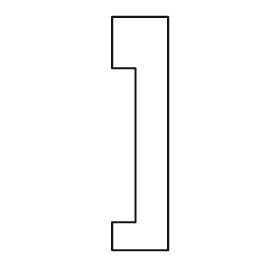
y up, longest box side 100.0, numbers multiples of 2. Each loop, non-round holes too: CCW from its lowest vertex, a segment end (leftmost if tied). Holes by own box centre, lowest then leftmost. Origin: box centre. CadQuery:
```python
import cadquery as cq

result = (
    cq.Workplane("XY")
    .moveTo(-12.0, -50.0)
    .lineTo(12.0, -50.0)
    .lineTo(12.0, 50.0)
    .lineTo(-12.0, 50.0)
    .lineTo(-12.0, 28.0)
    .lineTo(-2.0, 28.0)
    .lineTo(-2.0, -38.0)
    .lineTo(-12.0, -38.0)
    .close()
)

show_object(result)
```